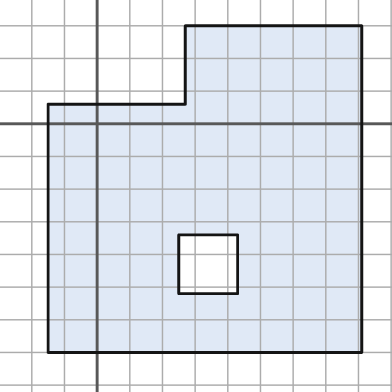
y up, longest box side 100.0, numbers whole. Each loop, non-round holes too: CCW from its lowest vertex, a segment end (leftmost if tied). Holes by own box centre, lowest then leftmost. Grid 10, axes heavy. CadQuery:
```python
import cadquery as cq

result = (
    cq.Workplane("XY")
    .moveTo(-15.0, -70.0)
    .lineTo(81.0, -70.0)
    .lineTo(81.0, 30.0)
    .lineTo(27.0, 30.0)
    .lineTo(27.0, 6.0)
    .lineTo(-15.0, 6.0)
    .close()
    .moveTo(25.0, -52.0)
    .lineTo(43.0, -52.0)
    .lineTo(43.0, -34.0)
    .lineTo(25.0, -34.0)
    .close()
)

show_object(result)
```